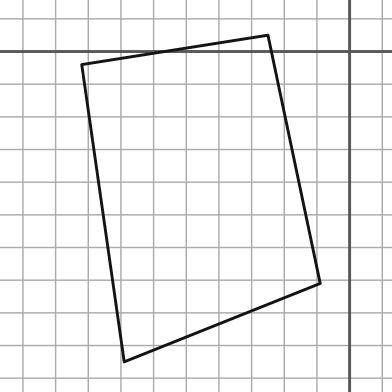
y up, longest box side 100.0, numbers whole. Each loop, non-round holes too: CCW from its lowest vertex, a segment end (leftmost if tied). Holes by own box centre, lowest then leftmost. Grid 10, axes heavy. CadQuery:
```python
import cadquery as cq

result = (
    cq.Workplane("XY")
    .moveTo(-69.0, -95.0)
    .lineTo(-9.0, -71.0)
    .lineTo(-25.0, 5.0)
    .lineTo(-82.0, -4.0)
    .close()
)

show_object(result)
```